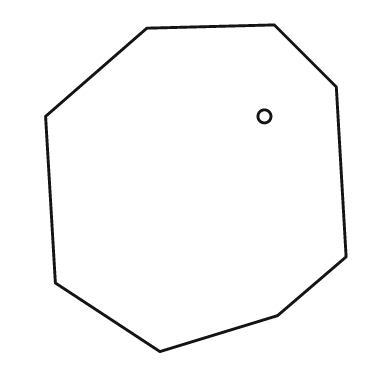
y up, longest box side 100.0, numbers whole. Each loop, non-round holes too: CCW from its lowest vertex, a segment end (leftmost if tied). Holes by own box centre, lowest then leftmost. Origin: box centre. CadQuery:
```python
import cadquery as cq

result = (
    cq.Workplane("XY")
    .moveTo(-11.0, -50.0)
    .lineTo(25.0, -39.0)
    .lineTo(46.0, -21.0)
    .lineTo(43.0, 31.0)
    .lineTo(24.0, 50.0)
    .lineTo(-15.0, 49.0)
    .lineTo(-46.0, 22.0)
    .lineTo(-43.0, -29.0)
    .close()
    .moveTo(21.0, 22.0)
    .circle(2.0)
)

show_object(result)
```